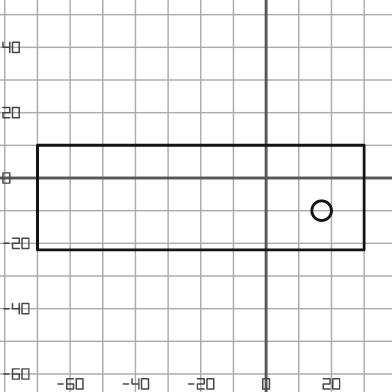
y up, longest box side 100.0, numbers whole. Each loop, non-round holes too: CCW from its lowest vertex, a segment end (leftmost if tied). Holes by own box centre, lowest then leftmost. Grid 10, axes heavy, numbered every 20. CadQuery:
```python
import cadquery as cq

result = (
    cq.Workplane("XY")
    .moveTo(-70.0, -22.0)
    .lineTo(30.0, -22.0)
    .lineTo(30.0, 10.0)
    .lineTo(-70.0, 10.0)
    .close()
    .moveTo(17.0, -10.0)
    .circle(3.0)
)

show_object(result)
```